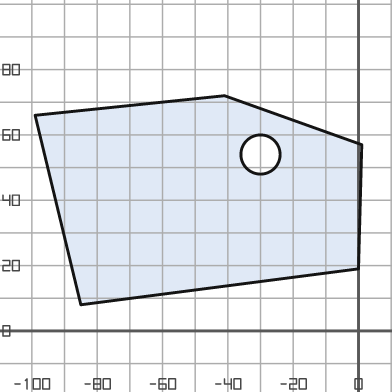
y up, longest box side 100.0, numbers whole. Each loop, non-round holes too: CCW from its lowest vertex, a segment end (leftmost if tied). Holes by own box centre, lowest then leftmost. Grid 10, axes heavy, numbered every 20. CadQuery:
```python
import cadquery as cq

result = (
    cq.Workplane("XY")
    .moveTo(-85.0, 8.0)
    .lineTo(0.0, 19.0)
    .lineTo(1.0, 57.0)
    .lineTo(-41.0, 72.0)
    .lineTo(-99.0, 66.0)
    .close()
    .moveTo(-30.0, 54.0)
    .circle(6.0)
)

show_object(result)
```